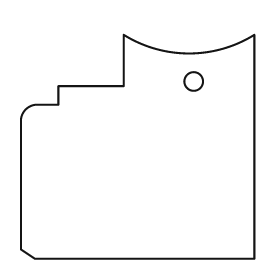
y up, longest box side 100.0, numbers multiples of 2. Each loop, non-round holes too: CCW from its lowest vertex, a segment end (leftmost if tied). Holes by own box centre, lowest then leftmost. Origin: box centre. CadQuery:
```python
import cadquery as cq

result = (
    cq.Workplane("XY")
    .moveTo(-44.0, -48.0)
    .lineTo(50.0, -48.0)
    .lineTo(50.0, 48.0)
    .threePointArc((22.0, 40.0), (-6.0, 48.0))
    .lineTo(-6.0, 26.0)
    .lineTo(-34.0, 26.0)
    .lineTo(-34.0, 18.0)
    .lineTo(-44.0, 18.0)
    .threePointArc((-48.0, 16.0), (-50.0, 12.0))
    .lineTo(-50.0, -44.0)
    .close()
    .moveTo(24.0, 28.0)
    .circle(4.0)
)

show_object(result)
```